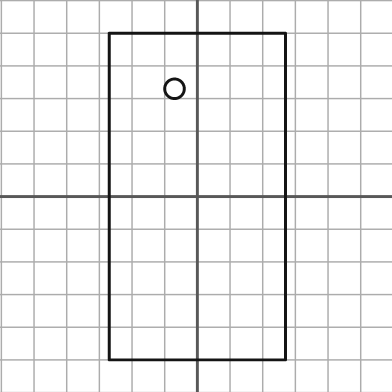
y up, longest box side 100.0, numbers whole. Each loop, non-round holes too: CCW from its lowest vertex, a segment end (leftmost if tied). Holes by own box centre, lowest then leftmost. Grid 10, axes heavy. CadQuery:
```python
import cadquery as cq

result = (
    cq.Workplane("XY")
    .moveTo(-27.0, -50.0)
    .lineTo(27.0, -50.0)
    .lineTo(27.0, 50.0)
    .lineTo(-27.0, 50.0)
    .close()
    .moveTo(-7.0, 33.0)
    .circle(3.0)
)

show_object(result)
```